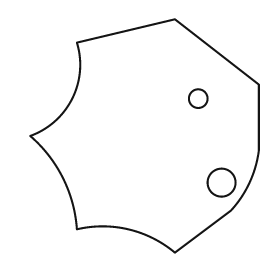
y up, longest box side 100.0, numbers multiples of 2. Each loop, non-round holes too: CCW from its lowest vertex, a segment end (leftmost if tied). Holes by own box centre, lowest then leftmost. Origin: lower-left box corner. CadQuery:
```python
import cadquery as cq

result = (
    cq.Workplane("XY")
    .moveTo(62.0, 0.0)
    .lineTo(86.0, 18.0)
    .threePointArc((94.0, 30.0), (98.0, 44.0))
    .lineTo(98.0, 72.0)
    .lineTo(62.0, 100.0)
    .lineTo(20.0, 90.0)
    .threePointArc((18.0, 66.0), (0.0, 50.0))
    .threePointArc((14.0, 32.0), (20.0, 10.0))
    .threePointArc((42.0, 10.0), (62.0, 0.0))
    .close()
    .moveTo(82.0, 30.0)
    .circle(6.0)
    .moveTo(72.0, 66.0)
    .circle(4.0)
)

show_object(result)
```